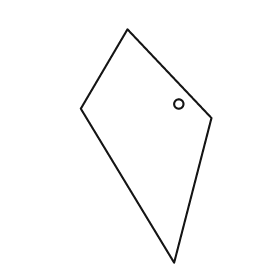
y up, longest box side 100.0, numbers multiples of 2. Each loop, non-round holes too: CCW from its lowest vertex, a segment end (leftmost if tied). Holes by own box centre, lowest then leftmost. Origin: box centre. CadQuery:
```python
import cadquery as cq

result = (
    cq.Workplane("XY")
    .moveTo(12.0, -50.0)
    .lineTo(28.0, 12.0)
    .lineTo(-8.0, 50.0)
    .lineTo(-28.0, 16.0)
    .close()
    .moveTo(14.0, 18.0)
    .circle(2.0)
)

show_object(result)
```